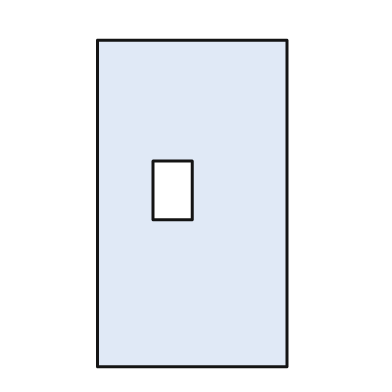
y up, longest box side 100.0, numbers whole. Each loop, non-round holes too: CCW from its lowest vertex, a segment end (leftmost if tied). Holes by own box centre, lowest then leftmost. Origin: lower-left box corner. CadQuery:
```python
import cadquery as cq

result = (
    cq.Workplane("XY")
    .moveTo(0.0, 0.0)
    .lineTo(58.0, 0.0)
    .lineTo(58.0, 100.0)
    .lineTo(0.0, 100.0)
    .close()
    .moveTo(17.0, 45.0)
    .lineTo(29.0, 45.0)
    .lineTo(29.0, 63.0)
    .lineTo(17.0, 63.0)
    .close()
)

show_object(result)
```